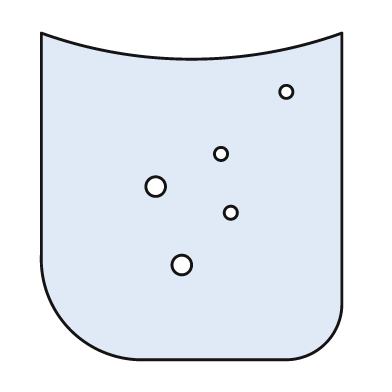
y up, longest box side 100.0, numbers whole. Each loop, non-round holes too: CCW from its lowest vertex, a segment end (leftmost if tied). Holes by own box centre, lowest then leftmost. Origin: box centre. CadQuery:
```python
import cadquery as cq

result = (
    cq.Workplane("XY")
    .moveTo(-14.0, -50.0)
    .lineTo(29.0, -50.0)
    .threePointArc((41.0, -45.0), (46.0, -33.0))
    .lineTo(46.0, 50.0)
    .threePointArc((0.0, 42.0), (-46.0, 50.0))
    .lineTo(-46.0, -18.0)
    .threePointArc((-37.0, -41.0), (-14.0, -50.0))
    .close()
    .moveTo(-3.0, -21.0)
    .circle(3.0)
    .moveTo(12.0, -5.0)
    .circle(2.0)
    .moveTo(-11.0, 3.0)
    .circle(3.0)
    .moveTo(9.0, 13.0)
    .circle(2.0)
    .moveTo(29.0, 32.0)
    .circle(2.0)
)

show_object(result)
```